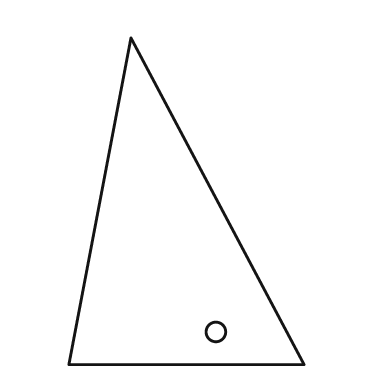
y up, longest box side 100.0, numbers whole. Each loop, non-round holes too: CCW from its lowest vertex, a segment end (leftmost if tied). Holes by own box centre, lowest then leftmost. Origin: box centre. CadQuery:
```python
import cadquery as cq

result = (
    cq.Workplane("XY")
    .moveTo(-36.0, -50.0)
    .lineTo(36.0, -50.0)
    .lineTo(-17.0, 50.0)
    .close()
    .moveTo(9.0, -40.0)
    .circle(3.0)
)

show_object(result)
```